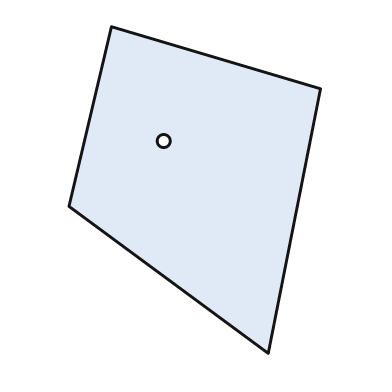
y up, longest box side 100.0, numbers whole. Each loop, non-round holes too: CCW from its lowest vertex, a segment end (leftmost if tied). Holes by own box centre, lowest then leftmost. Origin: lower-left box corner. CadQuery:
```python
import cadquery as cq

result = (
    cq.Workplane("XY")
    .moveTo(61.0, 0.0)
    .lineTo(77.0, 81.0)
    .lineTo(13.0, 100.0)
    .lineTo(0.0, 45.0)
    .close()
    .moveTo(29.0, 65.0)
    .circle(2.0)
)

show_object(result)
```